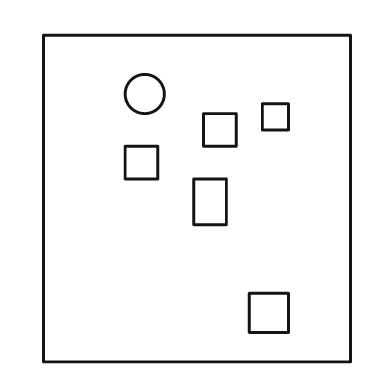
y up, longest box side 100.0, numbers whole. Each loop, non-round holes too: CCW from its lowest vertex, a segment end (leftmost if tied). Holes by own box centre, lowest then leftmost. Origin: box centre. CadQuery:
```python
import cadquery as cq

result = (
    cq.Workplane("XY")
    .moveTo(-47.0, -50.0)
    .lineTo(47.0, -50.0)
    .lineTo(47.0, 50.0)
    .lineTo(-47.0, 50.0)
    .close()
    .moveTo(16.0, -41.0)
    .lineTo(28.0, -41.0)
    .lineTo(28.0, -29.0)
    .lineTo(16.0, -29.0)
    .close()
    .moveTo(-1.0, -8.0)
    .lineTo(9.0, -8.0)
    .lineTo(9.0, 6.0)
    .lineTo(-1.0, 6.0)
    .close()
    .moveTo(-22.0, 6.0)
    .lineTo(-12.0, 6.0)
    .lineTo(-12.0, 16.0)
    .lineTo(-22.0, 16.0)
    .close()
    .moveTo(2.0, 16.0)
    .lineTo(12.0, 16.0)
    .lineTo(12.0, 26.0)
    .lineTo(2.0, 26.0)
    .close()
    .moveTo(20.0, 21.0)
    .lineTo(28.0, 21.0)
    .lineTo(28.0, 29.0)
    .lineTo(20.0, 29.0)
    .close()
    .moveTo(-16.0, 32.0)
    .circle(6.0)
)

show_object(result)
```